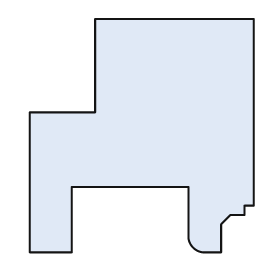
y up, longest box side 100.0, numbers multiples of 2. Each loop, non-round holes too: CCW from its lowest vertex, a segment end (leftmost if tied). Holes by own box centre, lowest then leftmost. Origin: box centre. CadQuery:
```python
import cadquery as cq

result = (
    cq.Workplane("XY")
    .moveTo(-48.0, -50.0)
    .lineTo(-30.0, -50.0)
    .lineTo(-30.0, -22.0)
    .lineTo(20.0, -22.0)
    .lineTo(20.0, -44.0)
    .threePointArc((22.0, -48.0), (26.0, -50.0))
    .lineTo(34.0, -50.0)
    .lineTo(34.0, -38.0)
    .lineTo(38.0, -34.0)
    .lineTo(44.0, -34.0)
    .lineTo(44.0, -30.0)
    .lineTo(48.0, -30.0)
    .lineTo(48.0, 50.0)
    .lineTo(-20.0, 50.0)
    .lineTo(-20.0, 10.0)
    .lineTo(-48.0, 10.0)
    .close()
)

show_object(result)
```